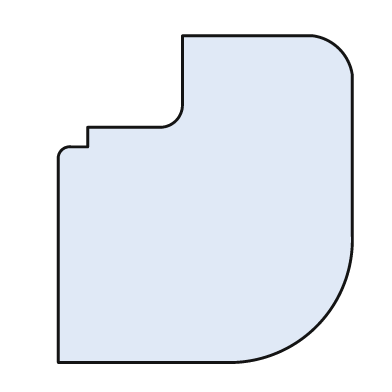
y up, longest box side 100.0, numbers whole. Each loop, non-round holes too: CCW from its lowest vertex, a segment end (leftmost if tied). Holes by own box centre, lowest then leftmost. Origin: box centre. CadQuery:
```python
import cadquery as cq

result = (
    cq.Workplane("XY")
    .moveTo(-45.0, -50.0)
    .lineTo(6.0, -50.0)
    .threePointArc((34.0, -39.0), (45.0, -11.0))
    .lineTo(45.0, 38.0)
    .threePointArc((41.0, 46.0), (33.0, 50.0))
    .lineTo(-7.0, 50.0)
    .lineTo(-7.0, 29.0)
    .threePointArc((-9.0, 24.0), (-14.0, 22.0))
    .lineTo(-36.0, 22.0)
    .lineTo(-36.0, 16.0)
    .lineTo(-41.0, 16.0)
    .threePointArc((-44.0, 15.0), (-45.0, 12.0))
    .close()
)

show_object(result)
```